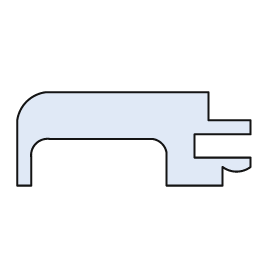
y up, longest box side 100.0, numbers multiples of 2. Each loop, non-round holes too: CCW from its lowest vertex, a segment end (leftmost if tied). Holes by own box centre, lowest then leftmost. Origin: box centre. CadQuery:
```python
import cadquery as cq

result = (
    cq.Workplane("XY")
    .moveTo(-50.0, -20.0)
    .lineTo(-44.0, -20.0)
    .lineTo(-44.0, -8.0)
    .threePointArc((-42.0, -2.0), (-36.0, 0.0))
    .lineTo(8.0, 0.0)
    .threePointArc((12.0, -2.0), (14.0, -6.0))
    .lineTo(14.0, -20.0)
    .lineTo(38.0, -20.0)
    .lineTo(38.0, -12.0)
    .threePointArc((44.0, -14.0), (50.0, -12.0))
    .lineTo(50.0, -8.0)
    .lineTo(26.0, -8.0)
    .lineTo(26.0, 2.0)
    .lineTo(50.0, 2.0)
    .lineTo(50.0, 8.0)
    .lineTo(32.0, 8.0)
    .lineTo(32.0, 20.0)
    .lineTo(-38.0, 20.0)
    .threePointArc((-46.0, 16.0), (-50.0, 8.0))
    .close()
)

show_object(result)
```